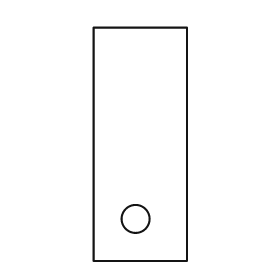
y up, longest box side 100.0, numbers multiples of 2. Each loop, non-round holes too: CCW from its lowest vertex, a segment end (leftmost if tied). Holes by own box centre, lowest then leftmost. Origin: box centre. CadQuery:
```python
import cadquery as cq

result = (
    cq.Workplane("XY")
    .moveTo(-20.0, -50.0)
    .lineTo(20.0, -50.0)
    .lineTo(20.0, 50.0)
    .lineTo(-20.0, 50.0)
    .close()
    .moveTo(-2.0, -32.0)
    .circle(6.0)
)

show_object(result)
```